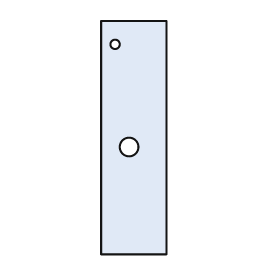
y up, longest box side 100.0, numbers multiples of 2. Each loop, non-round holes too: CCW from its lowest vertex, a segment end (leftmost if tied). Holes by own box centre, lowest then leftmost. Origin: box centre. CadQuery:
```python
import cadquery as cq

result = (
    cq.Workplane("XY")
    .moveTo(-14.0, -50.0)
    .lineTo(14.0, -50.0)
    .lineTo(14.0, 50.0)
    .lineTo(-14.0, 50.0)
    .close()
    .moveTo(-2.0, -4.0)
    .circle(4.0)
    .moveTo(-8.0, 40.0)
    .circle(2.0)
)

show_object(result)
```